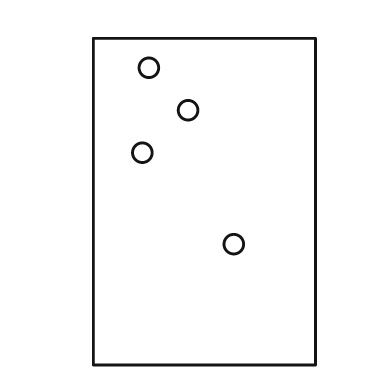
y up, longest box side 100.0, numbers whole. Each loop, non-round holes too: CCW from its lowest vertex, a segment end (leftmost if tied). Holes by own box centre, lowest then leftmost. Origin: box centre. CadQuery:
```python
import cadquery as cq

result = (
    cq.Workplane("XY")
    .moveTo(-34.0, -50.0)
    .lineTo(34.0, -50.0)
    .lineTo(34.0, 50.0)
    .lineTo(-34.0, 50.0)
    .close()
    .moveTo(9.0, -13.0)
    .circle(3.0)
    .moveTo(-19.0, 15.0)
    .circle(3.0)
    .moveTo(-5.0, 28.0)
    .circle(3.0)
    .moveTo(-17.0, 41.0)
    .circle(3.0)
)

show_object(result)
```